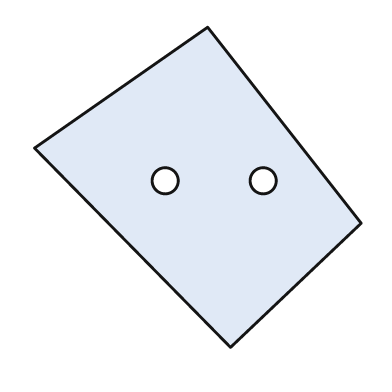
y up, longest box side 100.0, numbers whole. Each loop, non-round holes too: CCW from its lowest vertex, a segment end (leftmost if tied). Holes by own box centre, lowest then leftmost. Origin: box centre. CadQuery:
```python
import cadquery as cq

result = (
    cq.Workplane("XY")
    .moveTo(10.0, -49.0)
    .lineTo(50.0, -11.0)
    .lineTo(3.0, 49.0)
    .lineTo(-50.0, 12.0)
    .close()
    .moveTo(-10.0, 2.0)
    .circle(4.0)
    .moveTo(20.0, 2.0)
    .circle(4.0)
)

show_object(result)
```